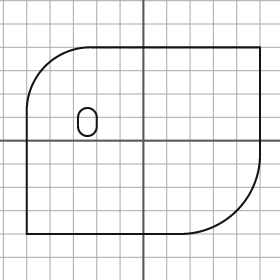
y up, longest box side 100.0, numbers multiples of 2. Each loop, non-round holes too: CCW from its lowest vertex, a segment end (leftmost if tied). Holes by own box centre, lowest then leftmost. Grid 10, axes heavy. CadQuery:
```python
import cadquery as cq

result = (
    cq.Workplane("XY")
    .moveTo(-50.0, -40.0)
    .lineTo(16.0, -40.0)
    .threePointArc((40.0, -30.0), (50.0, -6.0))
    .lineTo(50.0, 40.0)
    .lineTo(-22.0, 40.0)
    .threePointArc((-42.0, 32.0), (-50.0, 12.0))
    .close()
    .moveTo(-28.0, 6.0)
    .threePointArc((-24.0, 2.0), (-20.0, 6.0))
    .lineTo(-20.0, 10.0)
    .threePointArc((-24.0, 14.0), (-28.0, 10.0))
    .close()
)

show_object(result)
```